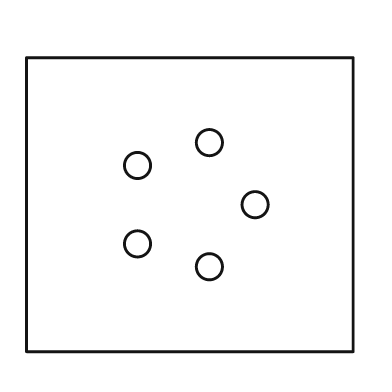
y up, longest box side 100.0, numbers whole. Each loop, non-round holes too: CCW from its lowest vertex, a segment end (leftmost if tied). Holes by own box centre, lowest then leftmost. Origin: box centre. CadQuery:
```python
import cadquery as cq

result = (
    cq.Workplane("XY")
    .moveTo(-50.0, -45.0)
    .lineTo(50.0, -45.0)
    .lineTo(50.0, 45.0)
    .lineTo(-50.0, 45.0)
    .close()
    .moveTo(6.0, -19.0)
    .circle(4.0)
    .moveTo(-16.0, -12.0)
    .circle(4.0)
    .moveTo(20.0, 0.0)
    .circle(4.0)
    .moveTo(-16.0, 12.0)
    .circle(4.0)
    .moveTo(6.0, 19.0)
    .circle(4.0)
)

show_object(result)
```